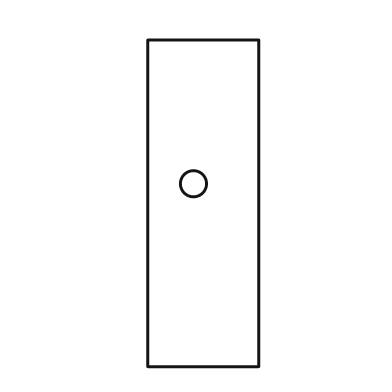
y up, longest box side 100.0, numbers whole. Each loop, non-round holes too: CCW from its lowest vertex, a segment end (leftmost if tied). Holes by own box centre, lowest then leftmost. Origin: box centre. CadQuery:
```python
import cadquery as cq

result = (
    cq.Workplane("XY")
    .moveTo(-17.0, -50.0)
    .lineTo(17.0, -50.0)
    .lineTo(17.0, 50.0)
    .lineTo(-17.0, 50.0)
    .close()
    .moveTo(-3.0, 6.0)
    .circle(4.0)
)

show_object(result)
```